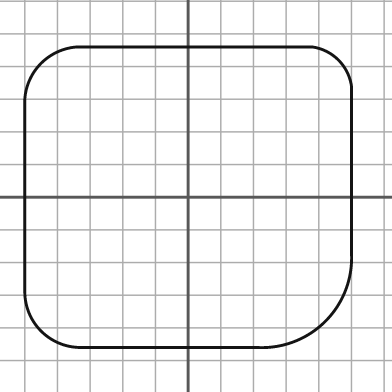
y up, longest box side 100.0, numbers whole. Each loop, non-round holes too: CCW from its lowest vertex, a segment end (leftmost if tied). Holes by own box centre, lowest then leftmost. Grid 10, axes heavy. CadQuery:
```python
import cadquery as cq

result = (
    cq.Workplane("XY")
    .moveTo(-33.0, -46.0)
    .lineTo(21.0, -46.0)
    .threePointArc((42.0, -38.0), (50.0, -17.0))
    .lineTo(50.0, 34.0)
    .threePointArc((46.0, 42.0), (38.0, 46.0))
    .lineTo(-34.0, 46.0)
    .threePointArc((-45.0, 41.0), (-50.0, 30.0))
    .lineTo(-50.0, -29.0)
    .threePointArc((-45.0, -41.0), (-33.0, -46.0))
    .close()
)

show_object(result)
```